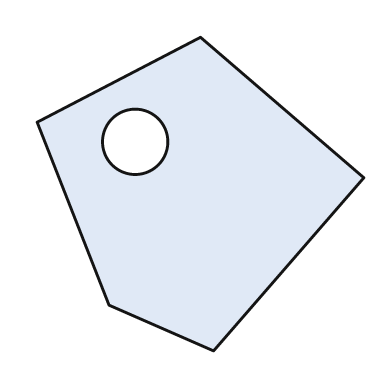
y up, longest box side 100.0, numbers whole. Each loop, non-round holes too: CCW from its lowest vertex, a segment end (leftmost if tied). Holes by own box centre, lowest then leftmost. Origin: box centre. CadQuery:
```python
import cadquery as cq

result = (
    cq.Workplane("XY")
    .moveTo(4.0, -48.0)
    .lineTo(50.0, 5.0)
    .lineTo(0.0, 48.0)
    .lineTo(-50.0, 22.0)
    .lineTo(-28.0, -34.0)
    .close()
    .moveTo(-20.0, 16.0)
    .circle(10.0)
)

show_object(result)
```